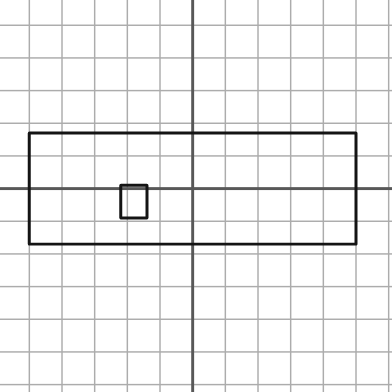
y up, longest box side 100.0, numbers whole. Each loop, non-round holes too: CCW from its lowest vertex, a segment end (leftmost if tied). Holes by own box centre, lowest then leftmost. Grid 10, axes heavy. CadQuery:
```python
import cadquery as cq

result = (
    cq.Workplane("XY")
    .moveTo(-50.0, -17.0)
    .lineTo(50.0, -17.0)
    .lineTo(50.0, 17.0)
    .lineTo(-50.0, 17.0)
    .close()
    .moveTo(-22.0, -9.0)
    .lineTo(-14.0, -9.0)
    .lineTo(-14.0, 1.0)
    .lineTo(-22.0, 1.0)
    .close()
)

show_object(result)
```